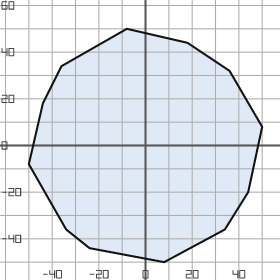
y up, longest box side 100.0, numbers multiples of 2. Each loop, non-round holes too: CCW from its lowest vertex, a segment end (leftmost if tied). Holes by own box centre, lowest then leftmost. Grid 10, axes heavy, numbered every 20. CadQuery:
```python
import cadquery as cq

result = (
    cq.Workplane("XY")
    .moveTo(8.0, -50.0)
    .lineTo(34.0, -36.0)
    .lineTo(44.0, -20.0)
    .lineTo(50.0, 8.0)
    .lineTo(36.0, 32.0)
    .lineTo(18.0, 44.0)
    .lineTo(-8.0, 50.0)
    .lineTo(-36.0, 34.0)
    .lineTo(-44.0, 18.0)
    .lineTo(-50.0, -8.0)
    .lineTo(-34.0, -36.0)
    .lineTo(-24.0, -44.0)
    .close()
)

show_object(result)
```